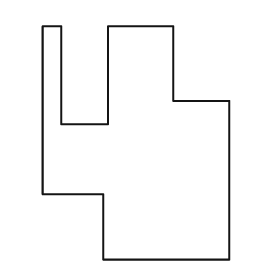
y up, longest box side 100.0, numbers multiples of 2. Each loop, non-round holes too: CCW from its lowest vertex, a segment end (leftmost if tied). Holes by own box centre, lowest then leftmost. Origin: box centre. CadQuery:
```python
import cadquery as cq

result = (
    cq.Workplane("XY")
    .moveTo(-14.0, -50.0)
    .lineTo(40.0, -50.0)
    .lineTo(40.0, 18.0)
    .lineTo(16.0, 18.0)
    .lineTo(16.0, 50.0)
    .lineTo(-12.0, 50.0)
    .lineTo(-12.0, 8.0)
    .lineTo(-32.0, 8.0)
    .lineTo(-32.0, 50.0)
    .lineTo(-40.0, 50.0)
    .lineTo(-40.0, -22.0)
    .lineTo(-14.0, -22.0)
    .close()
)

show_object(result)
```